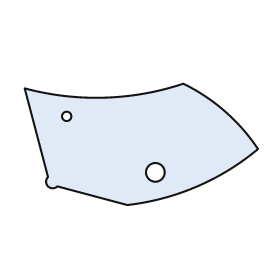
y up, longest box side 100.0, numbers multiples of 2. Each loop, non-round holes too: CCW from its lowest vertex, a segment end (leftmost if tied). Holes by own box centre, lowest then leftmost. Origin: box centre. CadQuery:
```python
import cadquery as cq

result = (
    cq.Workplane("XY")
    .moveTo(-6.0, -26.0)
    .threePointArc((24.0, -18.0), (50.0, -2.0))
    .threePointArc((36.0, 14.0), (18.0, 26.0))
    .threePointArc((-16.0, 20.0), (-50.0, 24.0))
    .lineTo(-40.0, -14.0)
    .threePointArc((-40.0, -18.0), (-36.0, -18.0))
    .close()
    .moveTo(6.0, -12.0)
    .circle(4.0)
    .moveTo(-32.0, 12.0)
    .circle(2.0)
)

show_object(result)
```